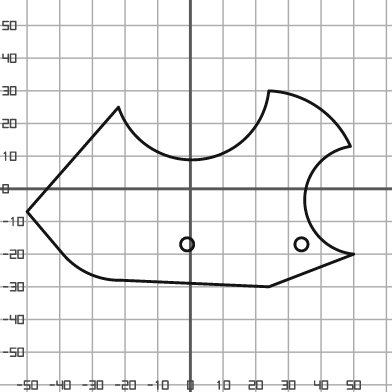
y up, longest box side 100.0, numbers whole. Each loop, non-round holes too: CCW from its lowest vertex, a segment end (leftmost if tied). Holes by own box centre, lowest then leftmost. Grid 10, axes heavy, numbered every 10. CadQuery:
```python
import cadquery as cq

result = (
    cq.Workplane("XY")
    .moveTo(24.0, -30.0)
    .lineTo(50.0, -20.0)
    .threePointArc((35.0, -4.0), (49.0, 13.0))
    .threePointArc((39.0, 25.0), (24.0, 30.0))
    .threePointArc((3.0, 9.0), (-22.0, 25.0))
    .lineTo(-50.0, -7.0)
    .lineTo(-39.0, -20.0)
    .threePointArc((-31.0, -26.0), (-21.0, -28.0))
    .close()
    .moveTo(-1.0, -17.0)
    .circle(2.0)
    .moveTo(34.0, -17.0)
    .circle(2.0)
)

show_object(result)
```